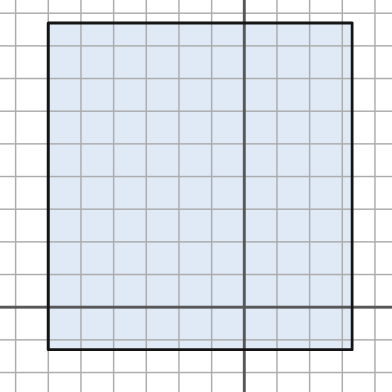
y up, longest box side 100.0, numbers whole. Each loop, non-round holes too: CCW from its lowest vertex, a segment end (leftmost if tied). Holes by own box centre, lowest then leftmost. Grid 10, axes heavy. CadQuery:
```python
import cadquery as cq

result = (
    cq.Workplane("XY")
    .moveTo(-60.0, -13.0)
    .lineTo(33.0, -13.0)
    .lineTo(33.0, 87.0)
    .lineTo(-60.0, 87.0)
    .close()
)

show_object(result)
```